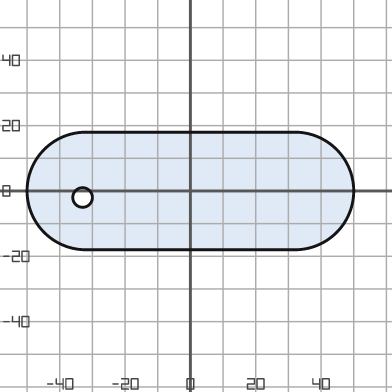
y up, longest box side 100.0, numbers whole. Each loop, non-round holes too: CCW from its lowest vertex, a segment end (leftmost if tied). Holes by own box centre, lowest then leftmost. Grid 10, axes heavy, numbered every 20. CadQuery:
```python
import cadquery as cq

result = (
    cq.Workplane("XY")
    .moveTo(-32.0, -18.0)
    .lineTo(32.0, -18.0)
    .threePointArc((50.0, 0.0), (32.0, 18.0))
    .lineTo(-32.0, 18.0)
    .threePointArc((-50.0, 0.0), (-32.0, -18.0))
    .close()
    .moveTo(-33.0, -2.0)
    .circle(3.0)
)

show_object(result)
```